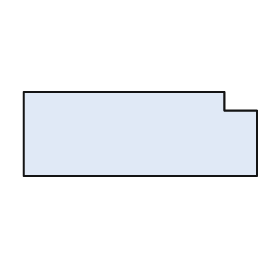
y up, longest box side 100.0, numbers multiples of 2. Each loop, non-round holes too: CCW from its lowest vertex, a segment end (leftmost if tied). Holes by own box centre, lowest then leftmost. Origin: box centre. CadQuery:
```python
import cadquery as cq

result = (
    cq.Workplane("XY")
    .moveTo(-50.0, -18.0)
    .lineTo(50.0, -18.0)
    .lineTo(50.0, 10.0)
    .lineTo(36.0, 10.0)
    .lineTo(36.0, 18.0)
    .lineTo(-50.0, 18.0)
    .close()
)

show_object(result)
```